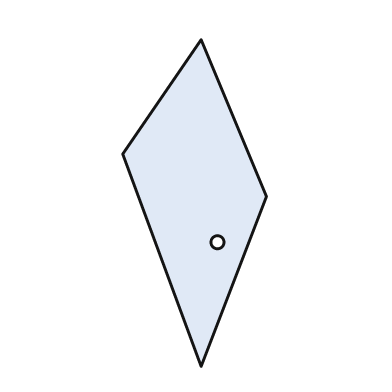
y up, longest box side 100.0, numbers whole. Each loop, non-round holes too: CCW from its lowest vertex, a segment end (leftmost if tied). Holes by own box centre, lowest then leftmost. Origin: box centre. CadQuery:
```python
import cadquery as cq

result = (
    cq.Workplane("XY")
    .moveTo(2.0, -50.0)
    .lineTo(22.0, 2.0)
    .lineTo(2.0, 50.0)
    .lineTo(-22.0, 15.0)
    .close()
    .moveTo(7.0, -12.0)
    .circle(2.0)
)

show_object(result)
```